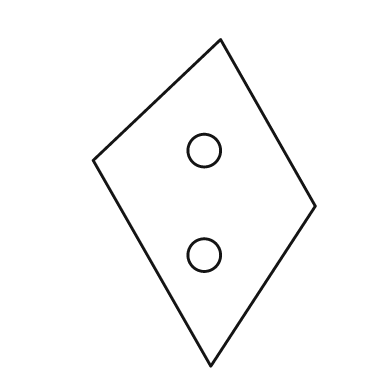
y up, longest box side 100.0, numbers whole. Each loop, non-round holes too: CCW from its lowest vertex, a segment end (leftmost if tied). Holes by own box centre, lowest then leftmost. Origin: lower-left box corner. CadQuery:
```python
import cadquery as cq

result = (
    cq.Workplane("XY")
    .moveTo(36.0, 0.0)
    .lineTo(68.0, 49.0)
    .lineTo(39.0, 100.0)
    .lineTo(0.0, 63.0)
    .close()
    .moveTo(34.0, 34.0)
    .circle(5.0)
    .moveTo(34.0, 66.0)
    .circle(5.0)
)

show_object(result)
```